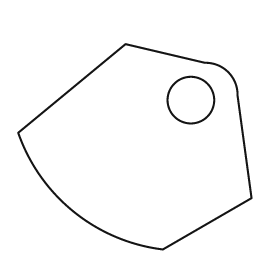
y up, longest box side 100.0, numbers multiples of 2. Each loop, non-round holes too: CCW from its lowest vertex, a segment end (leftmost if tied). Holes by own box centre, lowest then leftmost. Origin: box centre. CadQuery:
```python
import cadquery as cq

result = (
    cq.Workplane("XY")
    .moveTo(12.0, -44.0)
    .lineTo(50.0, -22.0)
    .lineTo(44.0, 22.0)
    .threePointArc((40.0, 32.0), (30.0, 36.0))
    .lineTo(-4.0, 44.0)
    .lineTo(-50.0, 6.0)
    .threePointArc((-26.0, -28.0), (12.0, -44.0))
    .close()
    .moveTo(24.0, 20.0)
    .circle(10.0)
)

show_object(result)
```